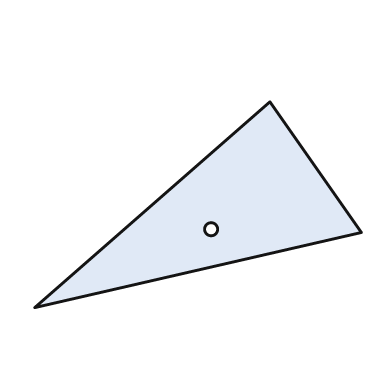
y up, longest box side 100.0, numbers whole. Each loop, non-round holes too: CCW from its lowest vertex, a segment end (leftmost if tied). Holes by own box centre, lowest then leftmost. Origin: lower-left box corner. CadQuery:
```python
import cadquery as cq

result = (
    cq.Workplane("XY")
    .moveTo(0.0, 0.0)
    .lineTo(100.0, 23.0)
    .lineTo(72.0, 63.0)
    .close()
    .moveTo(54.0, 24.0)
    .circle(2.0)
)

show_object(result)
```